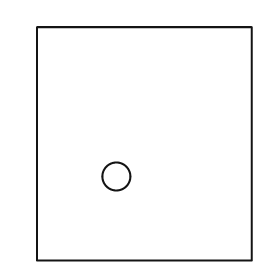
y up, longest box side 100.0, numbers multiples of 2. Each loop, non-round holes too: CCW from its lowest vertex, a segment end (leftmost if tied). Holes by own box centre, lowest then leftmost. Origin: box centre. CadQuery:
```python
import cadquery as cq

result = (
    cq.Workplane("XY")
    .moveTo(-46.0, -50.0)
    .lineTo(46.0, -50.0)
    .lineTo(46.0, 50.0)
    .lineTo(-46.0, 50.0)
    .close()
    .moveTo(-12.0, -14.0)
    .circle(6.0)
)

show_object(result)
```